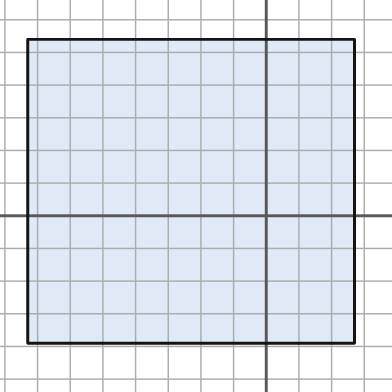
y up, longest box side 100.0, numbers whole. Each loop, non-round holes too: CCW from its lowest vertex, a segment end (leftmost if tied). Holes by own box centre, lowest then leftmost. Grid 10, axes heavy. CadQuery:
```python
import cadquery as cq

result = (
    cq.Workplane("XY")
    .moveTo(-73.0, -39.0)
    .lineTo(27.0, -39.0)
    .lineTo(27.0, 54.0)
    .lineTo(-73.0, 54.0)
    .close()
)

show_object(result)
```